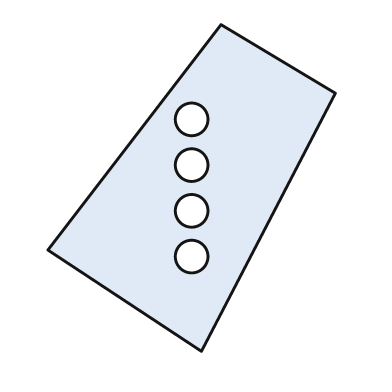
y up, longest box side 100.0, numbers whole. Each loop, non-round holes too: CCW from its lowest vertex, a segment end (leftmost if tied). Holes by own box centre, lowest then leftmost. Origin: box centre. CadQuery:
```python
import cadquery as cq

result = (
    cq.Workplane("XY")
    .moveTo(3.0, -50.0)
    .lineTo(44.0, 29.0)
    .lineTo(9.0, 50.0)
    .lineTo(-44.0, -19.0)
    .close()
    .moveTo(0.0, -21.0)
    .circle(5.0)
    .moveTo(0.0, -7.0)
    .circle(5.0)
    .moveTo(0.0, 7.0)
    .circle(5.0)
    .moveTo(0.0, 21.0)
    .circle(5.0)
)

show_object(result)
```